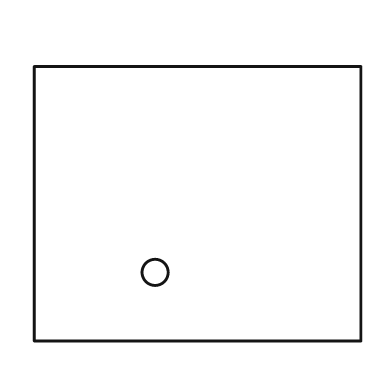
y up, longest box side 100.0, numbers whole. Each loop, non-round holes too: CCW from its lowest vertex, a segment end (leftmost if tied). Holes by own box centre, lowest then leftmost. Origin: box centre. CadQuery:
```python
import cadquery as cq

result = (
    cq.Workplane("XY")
    .moveTo(-50.0, -42.0)
    .lineTo(50.0, -42.0)
    .lineTo(50.0, 42.0)
    .lineTo(-50.0, 42.0)
    .close()
    .moveTo(-13.0, -21.0)
    .circle(4.0)
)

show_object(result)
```